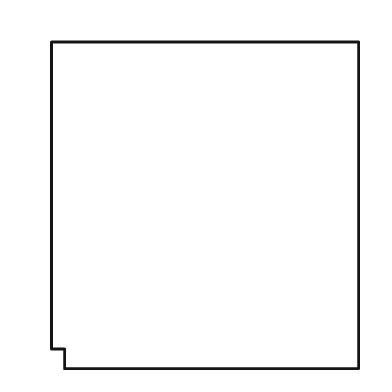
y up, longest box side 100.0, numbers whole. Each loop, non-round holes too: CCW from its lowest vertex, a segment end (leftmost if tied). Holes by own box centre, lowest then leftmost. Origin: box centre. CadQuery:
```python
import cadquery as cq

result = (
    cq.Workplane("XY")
    .moveTo(-43.0, -50.0)
    .lineTo(47.0, -50.0)
    .lineTo(47.0, 50.0)
    .lineTo(-47.0, 50.0)
    .lineTo(-47.0, -44.0)
    .lineTo(-43.0, -44.0)
    .close()
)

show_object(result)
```